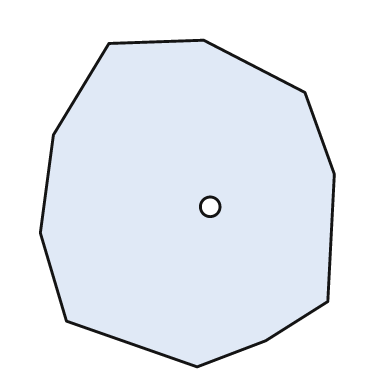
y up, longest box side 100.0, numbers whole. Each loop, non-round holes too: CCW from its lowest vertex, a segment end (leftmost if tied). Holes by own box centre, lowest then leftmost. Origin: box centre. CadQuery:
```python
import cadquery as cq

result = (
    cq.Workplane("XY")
    .moveTo(3.0, -50.0)
    .lineTo(24.0, -42.0)
    .lineTo(43.0, -30.0)
    .lineTo(45.0, 9.0)
    .lineTo(36.0, 34.0)
    .lineTo(5.0, 50.0)
    .lineTo(-24.0, 49.0)
    .lineTo(-41.0, 21.0)
    .lineTo(-45.0, -9.0)
    .lineTo(-37.0, -36.0)
    .close()
    .moveTo(7.0, -1.0)
    .circle(3.0)
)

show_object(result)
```